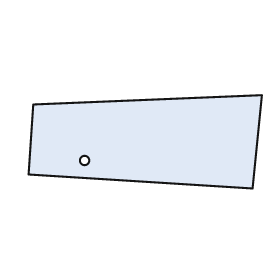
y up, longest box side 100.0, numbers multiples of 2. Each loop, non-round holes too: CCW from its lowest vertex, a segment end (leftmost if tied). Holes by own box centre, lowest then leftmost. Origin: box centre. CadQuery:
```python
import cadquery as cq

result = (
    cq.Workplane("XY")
    .moveTo(46.0, -20.0)
    .lineTo(50.0, 20.0)
    .lineTo(-48.0, 16.0)
    .lineTo(-50.0, -14.0)
    .close()
    .moveTo(-26.0, -8.0)
    .circle(2.0)
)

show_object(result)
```